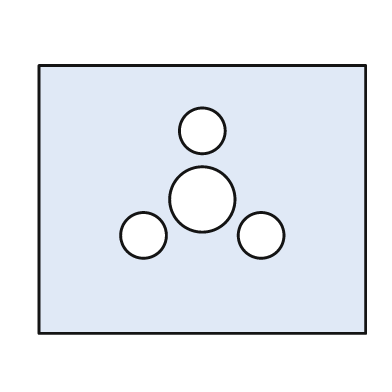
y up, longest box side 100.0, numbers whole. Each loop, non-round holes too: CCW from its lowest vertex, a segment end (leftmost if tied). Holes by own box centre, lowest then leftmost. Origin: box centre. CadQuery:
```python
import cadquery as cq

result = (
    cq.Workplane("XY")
    .moveTo(-50.0, -41.0)
    .lineTo(50.0, -41.0)
    .lineTo(50.0, 41.0)
    .lineTo(-50.0, 41.0)
    .close()
    .moveTo(-18.0, -11.0)
    .circle(7.0)
    .moveTo(18.0, -11.0)
    .circle(7.0)
    .moveTo(0.0, 0.0)
    .circle(10.0)
    .moveTo(0.0, 21.0)
    .circle(7.0)
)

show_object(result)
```